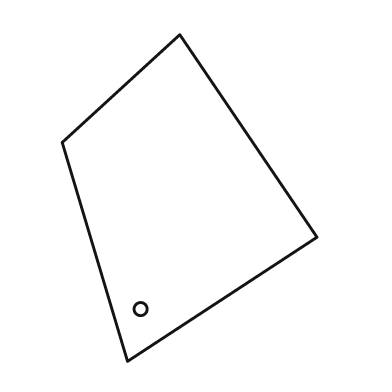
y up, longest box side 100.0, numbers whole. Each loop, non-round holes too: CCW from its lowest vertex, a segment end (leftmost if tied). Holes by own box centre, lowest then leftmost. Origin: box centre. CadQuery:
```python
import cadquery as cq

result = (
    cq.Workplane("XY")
    .moveTo(-19.0, -50.0)
    .lineTo(39.0, -12.0)
    .lineTo(-3.0, 50.0)
    .lineTo(-39.0, 17.0)
    .close()
    .moveTo(-15.0, -34.0)
    .circle(2.0)
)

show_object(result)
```